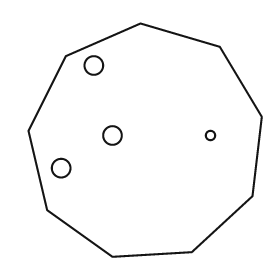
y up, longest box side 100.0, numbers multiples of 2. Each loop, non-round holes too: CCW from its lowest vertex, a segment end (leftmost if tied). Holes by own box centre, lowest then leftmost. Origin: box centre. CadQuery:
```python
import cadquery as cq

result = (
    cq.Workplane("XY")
    .moveTo(-14.0, -50.0)
    .lineTo(20.0, -48.0)
    .lineTo(46.0, -24.0)
    .lineTo(50.0, 10.0)
    .lineTo(32.0, 40.0)
    .lineTo(-2.0, 50.0)
    .lineTo(-34.0, 36.0)
    .lineTo(-50.0, 4.0)
    .lineTo(-42.0, -30.0)
    .close()
    .moveTo(-36.0, -12.0)
    .circle(4.0)
    .moveTo(-14.0, 2.0)
    .circle(4.0)
    .moveTo(28.0, 2.0)
    .circle(2.0)
    .moveTo(-22.0, 32.0)
    .circle(4.0)
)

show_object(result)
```